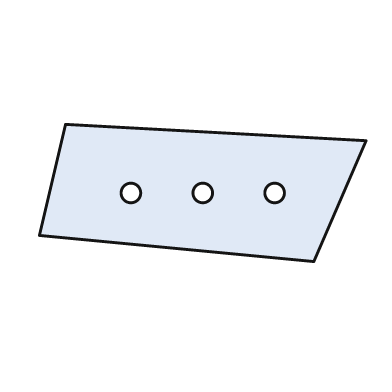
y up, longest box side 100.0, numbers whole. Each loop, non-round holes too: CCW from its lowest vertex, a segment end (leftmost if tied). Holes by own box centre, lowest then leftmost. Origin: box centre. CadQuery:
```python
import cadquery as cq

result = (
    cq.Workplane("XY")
    .moveTo(34.0, -21.0)
    .lineTo(50.0, 16.0)
    .lineTo(-42.0, 21.0)
    .lineTo(-50.0, -13.0)
    .close()
    .moveTo(-22.0, 0.0)
    .circle(3.0)
    .moveTo(0.0, 0.0)
    .circle(3.0)
    .moveTo(22.0, 0.0)
    .circle(3.0)
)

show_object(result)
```